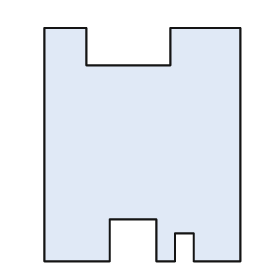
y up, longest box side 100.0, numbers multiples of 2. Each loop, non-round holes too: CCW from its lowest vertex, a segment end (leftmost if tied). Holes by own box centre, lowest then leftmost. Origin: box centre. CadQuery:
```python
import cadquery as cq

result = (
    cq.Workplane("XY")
    .moveTo(-42.0, -50.0)
    .lineTo(-14.0, -50.0)
    .lineTo(-14.0, -32.0)
    .lineTo(6.0, -32.0)
    .lineTo(6.0, -50.0)
    .lineTo(14.0, -50.0)
    .lineTo(14.0, -38.0)
    .lineTo(22.0, -38.0)
    .lineTo(22.0, -50.0)
    .lineTo(42.0, -50.0)
    .lineTo(42.0, 50.0)
    .lineTo(12.0, 50.0)
    .lineTo(12.0, 34.0)
    .lineTo(-24.0, 34.0)
    .lineTo(-24.0, 50.0)
    .lineTo(-42.0, 50.0)
    .close()
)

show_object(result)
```